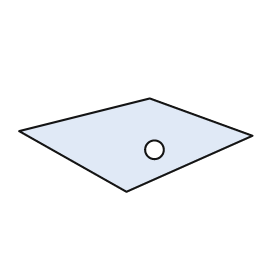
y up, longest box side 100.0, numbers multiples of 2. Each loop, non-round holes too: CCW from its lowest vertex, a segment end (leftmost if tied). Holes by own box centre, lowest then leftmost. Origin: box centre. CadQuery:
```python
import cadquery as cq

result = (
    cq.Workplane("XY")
    .moveTo(-4.0, -20.0)
    .lineTo(50.0, 4.0)
    .lineTo(6.0, 20.0)
    .lineTo(-50.0, 6.0)
    .close()
    .moveTo(8.0, -2.0)
    .circle(4.0)
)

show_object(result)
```